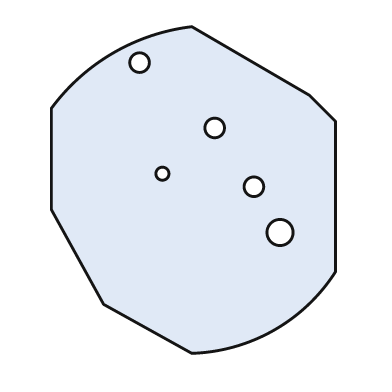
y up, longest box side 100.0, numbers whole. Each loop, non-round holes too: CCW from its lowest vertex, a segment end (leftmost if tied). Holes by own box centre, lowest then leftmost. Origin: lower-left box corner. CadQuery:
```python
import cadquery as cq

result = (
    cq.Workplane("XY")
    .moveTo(43.0, 0.0)
    .threePointArc((68.0, 7.0), (87.0, 25.0))
    .lineTo(87.0, 71.0)
    .lineTo(79.0, 79.0)
    .lineTo(43.0, 100.0)
    .threePointArc((19.0, 92.0), (0.0, 75.0))
    .lineTo(0.0, 44.0)
    .lineTo(16.0, 15.0)
    .close()
    .moveTo(70.0, 37.0)
    .circle(4.0)
    .moveTo(62.0, 51.0)
    .circle(3.0)
    .moveTo(34.0, 55.0)
    .circle(2.0)
    .moveTo(50.0, 69.0)
    .circle(3.0)
    .moveTo(27.0, 89.0)
    .circle(3.0)
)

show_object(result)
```